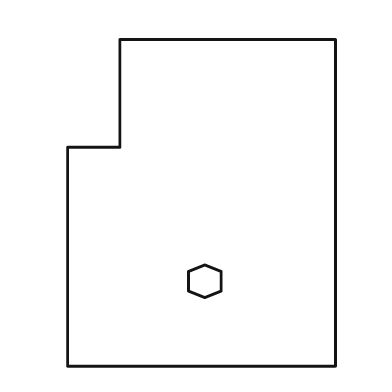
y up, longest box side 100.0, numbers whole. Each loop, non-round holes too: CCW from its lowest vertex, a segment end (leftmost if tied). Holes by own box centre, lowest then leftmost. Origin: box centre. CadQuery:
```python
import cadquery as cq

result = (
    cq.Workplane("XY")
    .moveTo(-41.0, -50.0)
    .lineTo(41.0, -50.0)
    .lineTo(41.0, 50.0)
    .lineTo(-25.0, 50.0)
    .lineTo(-25.0, 17.0)
    .lineTo(-41.0, 17.0)
    .close()
    .moveTo(1.0, -29.0)
    .lineTo(6.0, -27.0)
    .lineTo(6.0, -21.0)
    .lineTo(1.0, -19.0)
    .lineTo(-4.0, -21.0)
    .lineTo(-4.0, -27.0)
    .close()
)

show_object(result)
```